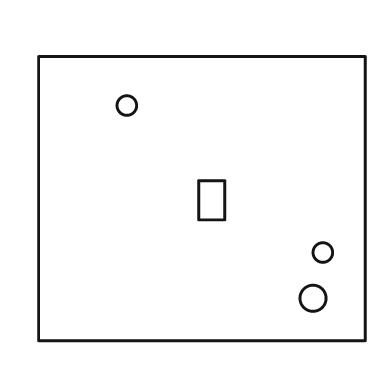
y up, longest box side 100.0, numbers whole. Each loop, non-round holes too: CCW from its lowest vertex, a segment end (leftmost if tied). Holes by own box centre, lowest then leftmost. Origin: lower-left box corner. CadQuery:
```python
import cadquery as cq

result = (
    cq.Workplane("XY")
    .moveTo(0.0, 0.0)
    .lineTo(100.0, 0.0)
    .lineTo(100.0, 87.0)
    .lineTo(0.0, 87.0)
    .close()
    .moveTo(84.0, 13.0)
    .circle(4.0)
    .moveTo(87.0, 27.0)
    .circle(3.0)
    .moveTo(49.0, 37.0)
    .lineTo(57.0, 37.0)
    .lineTo(57.0, 49.0)
    .lineTo(49.0, 49.0)
    .close()
    .moveTo(27.0, 72.0)
    .circle(3.0)
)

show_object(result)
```